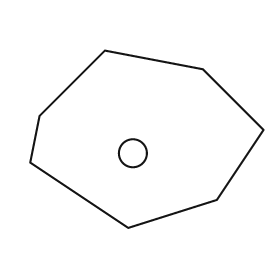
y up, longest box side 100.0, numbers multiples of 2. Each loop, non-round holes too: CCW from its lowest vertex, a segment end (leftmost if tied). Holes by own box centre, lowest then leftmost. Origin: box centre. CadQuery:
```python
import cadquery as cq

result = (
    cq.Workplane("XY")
    .moveTo(-8.0, -38.0)
    .lineTo(30.0, -26.0)
    .lineTo(50.0, 4.0)
    .lineTo(24.0, 30.0)
    .lineTo(-18.0, 38.0)
    .lineTo(-46.0, 10.0)
    .lineTo(-50.0, -10.0)
    .close()
    .moveTo(-6.0, -6.0)
    .circle(6.0)
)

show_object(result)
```